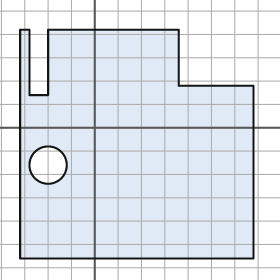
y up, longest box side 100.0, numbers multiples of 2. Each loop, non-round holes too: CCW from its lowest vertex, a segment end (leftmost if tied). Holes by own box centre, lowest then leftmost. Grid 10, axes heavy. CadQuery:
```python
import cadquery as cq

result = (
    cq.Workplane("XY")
    .moveTo(-32.0, -56.0)
    .lineTo(68.0, -56.0)
    .lineTo(68.0, 18.0)
    .lineTo(36.0, 18.0)
    .lineTo(36.0, 42.0)
    .lineTo(-20.0, 42.0)
    .lineTo(-20.0, 14.0)
    .lineTo(-28.0, 14.0)
    .lineTo(-28.0, 42.0)
    .lineTo(-32.0, 42.0)
    .close()
    .moveTo(-20.0, -16.0)
    .circle(8.0)
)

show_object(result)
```